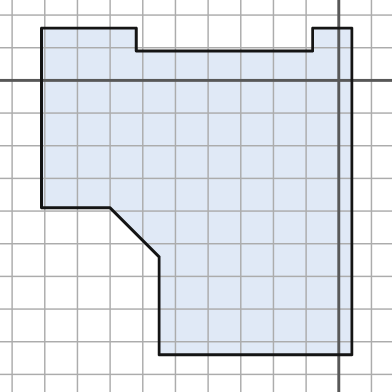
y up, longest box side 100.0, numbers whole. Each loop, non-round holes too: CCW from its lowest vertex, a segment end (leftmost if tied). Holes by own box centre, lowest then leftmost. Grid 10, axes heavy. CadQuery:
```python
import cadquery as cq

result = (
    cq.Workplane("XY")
    .moveTo(-55.0, -84.0)
    .lineTo(4.0, -84.0)
    .lineTo(4.0, 16.0)
    .lineTo(-8.0, 16.0)
    .lineTo(-8.0, 9.0)
    .lineTo(-62.0, 9.0)
    .lineTo(-62.0, 16.0)
    .lineTo(-91.0, 16.0)
    .lineTo(-91.0, -39.0)
    .lineTo(-70.0, -39.0)
    .lineTo(-55.0, -54.0)
    .close()
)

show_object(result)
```